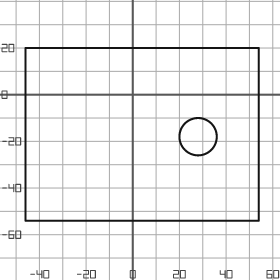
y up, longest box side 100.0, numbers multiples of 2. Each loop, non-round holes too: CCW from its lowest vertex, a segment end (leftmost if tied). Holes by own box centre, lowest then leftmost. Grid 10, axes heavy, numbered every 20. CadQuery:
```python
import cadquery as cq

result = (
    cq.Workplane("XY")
    .moveTo(-46.0, -54.0)
    .lineTo(54.0, -54.0)
    .lineTo(54.0, 20.0)
    .lineTo(-46.0, 20.0)
    .close()
    .moveTo(28.0, -18.0)
    .circle(8.0)
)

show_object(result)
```